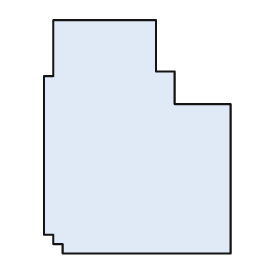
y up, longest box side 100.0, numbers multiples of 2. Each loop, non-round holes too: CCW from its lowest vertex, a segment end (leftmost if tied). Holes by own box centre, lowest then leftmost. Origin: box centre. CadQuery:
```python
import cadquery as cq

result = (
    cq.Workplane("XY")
    .moveTo(-32.0, -50.0)
    .lineTo(40.0, -50.0)
    .lineTo(40.0, 14.0)
    .lineTo(16.0, 14.0)
    .lineTo(16.0, 28.0)
    .lineTo(8.0, 28.0)
    .lineTo(8.0, 50.0)
    .lineTo(-36.0, 50.0)
    .lineTo(-36.0, 26.0)
    .lineTo(-40.0, 26.0)
    .lineTo(-40.0, -42.0)
    .lineTo(-36.0, -42.0)
    .lineTo(-36.0, -46.0)
    .lineTo(-32.0, -46.0)
    .close()
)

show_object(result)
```